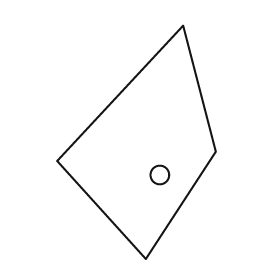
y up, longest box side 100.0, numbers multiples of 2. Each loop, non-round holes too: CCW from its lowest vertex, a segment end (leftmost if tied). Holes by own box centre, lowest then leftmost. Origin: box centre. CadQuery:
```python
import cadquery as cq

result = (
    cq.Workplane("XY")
    .moveTo(4.0, -50.0)
    .lineTo(34.0, -4.0)
    .lineTo(20.0, 50.0)
    .lineTo(-34.0, -8.0)
    .close()
    .moveTo(10.0, -14.0)
    .circle(4.0)
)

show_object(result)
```